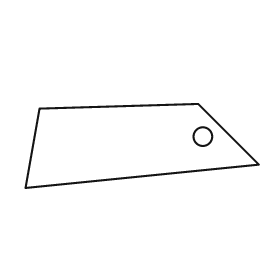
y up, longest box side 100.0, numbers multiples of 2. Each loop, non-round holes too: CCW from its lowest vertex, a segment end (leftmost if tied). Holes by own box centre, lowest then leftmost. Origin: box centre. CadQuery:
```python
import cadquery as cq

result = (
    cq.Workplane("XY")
    .moveTo(-50.0, -18.0)
    .lineTo(50.0, -8.0)
    .lineTo(24.0, 18.0)
    .lineTo(-44.0, 16.0)
    .close()
    .moveTo(26.0, 4.0)
    .circle(4.0)
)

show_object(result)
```